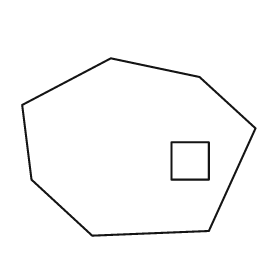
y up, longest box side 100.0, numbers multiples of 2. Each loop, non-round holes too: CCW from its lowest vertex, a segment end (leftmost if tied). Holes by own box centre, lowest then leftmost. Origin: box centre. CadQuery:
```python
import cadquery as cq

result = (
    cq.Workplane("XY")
    .moveTo(-20.0, -38.0)
    .lineTo(30.0, -36.0)
    .lineTo(50.0, 8.0)
    .lineTo(26.0, 30.0)
    .lineTo(-12.0, 38.0)
    .lineTo(-50.0, 18.0)
    .lineTo(-46.0, -14.0)
    .close()
    .moveTo(14.0, -14.0)
    .lineTo(30.0, -14.0)
    .lineTo(30.0, 2.0)
    .lineTo(14.0, 2.0)
    .close()
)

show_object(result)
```